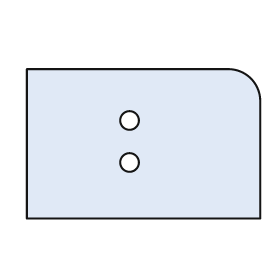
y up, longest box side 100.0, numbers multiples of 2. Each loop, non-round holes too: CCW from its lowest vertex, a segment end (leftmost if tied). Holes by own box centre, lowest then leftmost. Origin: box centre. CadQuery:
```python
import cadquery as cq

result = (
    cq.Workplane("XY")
    .moveTo(-50.0, -32.0)
    .lineTo(50.0, -32.0)
    .lineTo(50.0, 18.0)
    .threePointArc((46.0, 28.0), (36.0, 32.0))
    .lineTo(-50.0, 32.0)
    .close()
    .moveTo(-6.0, -8.0)
    .circle(4.0)
    .moveTo(-6.0, 10.0)
    .circle(4.0)
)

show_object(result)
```